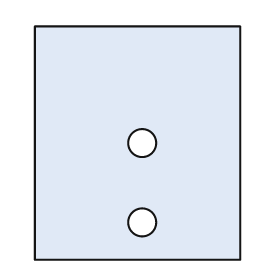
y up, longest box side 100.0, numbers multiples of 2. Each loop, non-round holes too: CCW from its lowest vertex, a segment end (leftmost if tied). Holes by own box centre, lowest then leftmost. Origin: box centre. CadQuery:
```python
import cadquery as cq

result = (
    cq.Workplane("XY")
    .moveTo(-44.0, -50.0)
    .lineTo(44.0, -50.0)
    .lineTo(44.0, 50.0)
    .lineTo(-44.0, 50.0)
    .close()
    .moveTo(2.0, -34.0)
    .circle(6.0)
    .moveTo(2.0, 0.0)
    .circle(6.0)
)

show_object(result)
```